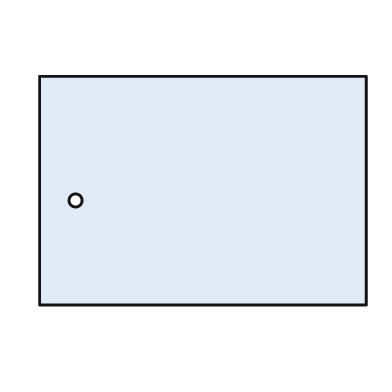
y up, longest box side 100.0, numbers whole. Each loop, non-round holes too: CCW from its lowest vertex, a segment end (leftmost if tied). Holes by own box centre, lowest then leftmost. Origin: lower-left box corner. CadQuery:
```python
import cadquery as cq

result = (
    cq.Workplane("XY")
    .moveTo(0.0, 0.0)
    .lineTo(100.0, 0.0)
    .lineTo(100.0, 70.0)
    .lineTo(0.0, 70.0)
    .close()
    .moveTo(11.0, 32.0)
    .circle(2.0)
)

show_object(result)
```